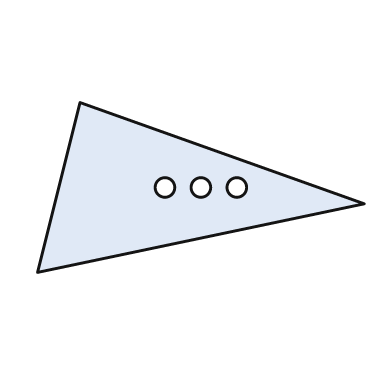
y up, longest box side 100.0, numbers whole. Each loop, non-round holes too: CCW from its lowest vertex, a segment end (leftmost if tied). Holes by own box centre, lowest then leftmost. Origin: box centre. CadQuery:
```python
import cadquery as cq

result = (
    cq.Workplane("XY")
    .moveTo(-50.0, -26.0)
    .lineTo(50.0, -5.0)
    .lineTo(-37.0, 26.0)
    .close()
    .moveTo(-11.0, 0.0)
    .circle(3.0)
    .moveTo(0.0, 0.0)
    .circle(3.0)
    .moveTo(11.0, 0.0)
    .circle(3.0)
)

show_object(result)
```